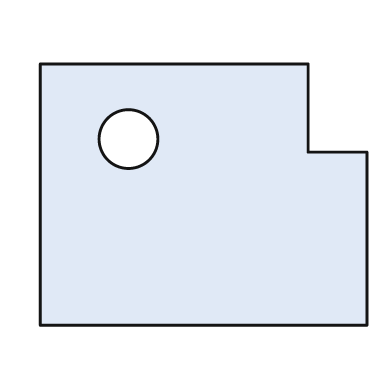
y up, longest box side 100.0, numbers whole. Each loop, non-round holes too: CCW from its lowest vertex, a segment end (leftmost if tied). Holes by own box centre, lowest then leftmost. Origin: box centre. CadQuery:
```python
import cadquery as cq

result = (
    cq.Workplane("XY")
    .moveTo(-50.0, -40.0)
    .lineTo(50.0, -40.0)
    .lineTo(50.0, 13.0)
    .lineTo(32.0, 13.0)
    .lineTo(32.0, 40.0)
    .lineTo(-50.0, 40.0)
    .close()
    .moveTo(-23.0, 17.0)
    .circle(9.0)
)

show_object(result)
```